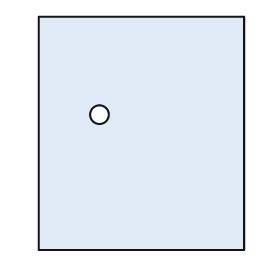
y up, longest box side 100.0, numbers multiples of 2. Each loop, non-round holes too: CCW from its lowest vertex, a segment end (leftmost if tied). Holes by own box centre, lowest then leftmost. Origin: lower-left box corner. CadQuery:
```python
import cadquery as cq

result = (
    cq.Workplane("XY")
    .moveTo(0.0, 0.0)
    .lineTo(88.0, 0.0)
    .lineTo(88.0, 100.0)
    .lineTo(0.0, 100.0)
    .close()
    .moveTo(26.0, 58.0)
    .circle(4.0)
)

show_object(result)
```